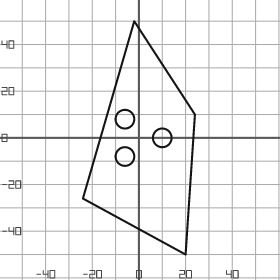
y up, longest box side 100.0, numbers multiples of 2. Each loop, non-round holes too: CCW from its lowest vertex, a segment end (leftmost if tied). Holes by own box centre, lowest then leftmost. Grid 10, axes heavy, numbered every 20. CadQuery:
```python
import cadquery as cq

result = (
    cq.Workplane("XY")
    .moveTo(20.0, -50.0)
    .lineTo(24.0, 10.0)
    .lineTo(-2.0, 50.0)
    .lineTo(-24.0, -26.0)
    .close()
    .moveTo(-6.0, -8.0)
    .circle(4.0)
    .moveTo(10.0, 0.0)
    .circle(4.0)
    .moveTo(-6.0, 8.0)
    .circle(4.0)
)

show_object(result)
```